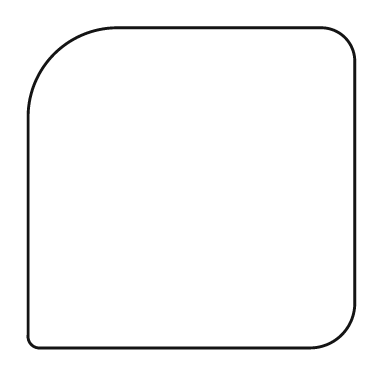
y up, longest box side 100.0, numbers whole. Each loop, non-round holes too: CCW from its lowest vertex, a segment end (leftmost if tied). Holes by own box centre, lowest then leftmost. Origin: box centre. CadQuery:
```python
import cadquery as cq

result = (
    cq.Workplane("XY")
    .moveTo(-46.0, -49.0)
    .lineTo(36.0, -49.0)
    .threePointArc((46.0, -45.0), (50.0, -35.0))
    .lineTo(50.0, 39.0)
    .threePointArc((47.0, 46.0), (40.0, 49.0))
    .lineTo(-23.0, 49.0)
    .threePointArc((-42.0, 41.0), (-50.0, 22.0))
    .lineTo(-50.0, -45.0)
    .threePointArc((-49.0, -48.0), (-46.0, -49.0))
    .close()
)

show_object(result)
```